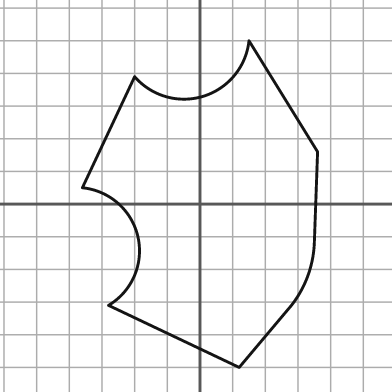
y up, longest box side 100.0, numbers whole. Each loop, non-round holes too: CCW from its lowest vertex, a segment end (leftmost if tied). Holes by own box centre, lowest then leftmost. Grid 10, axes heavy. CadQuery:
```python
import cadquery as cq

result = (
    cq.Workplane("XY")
    .moveTo(12.0, -50.0)
    .lineTo(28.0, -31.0)
    .threePointArc((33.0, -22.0), (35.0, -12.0))
    .lineTo(36.0, 16.0)
    .lineTo(15.0, 50.0)
    .threePointArc((1.0, 33.0), (-20.0, 39.0))
    .lineTo(-36.0, 5.0)
    .threePointArc((-19.0, -10.0), (-28.0, -31.0))
    .close()
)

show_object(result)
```